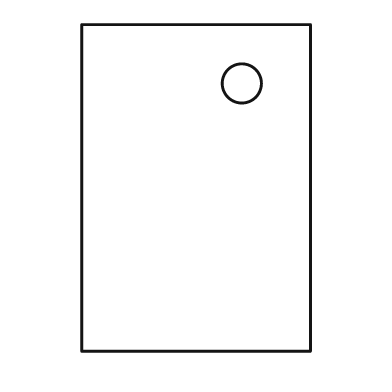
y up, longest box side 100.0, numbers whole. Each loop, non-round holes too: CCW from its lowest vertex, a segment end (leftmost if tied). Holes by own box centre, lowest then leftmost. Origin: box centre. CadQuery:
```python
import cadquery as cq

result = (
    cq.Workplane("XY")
    .moveTo(-35.0, -50.0)
    .lineTo(35.0, -50.0)
    .lineTo(35.0, 50.0)
    .lineTo(-35.0, 50.0)
    .close()
    .moveTo(14.0, 32.0)
    .circle(6.0)
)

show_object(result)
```